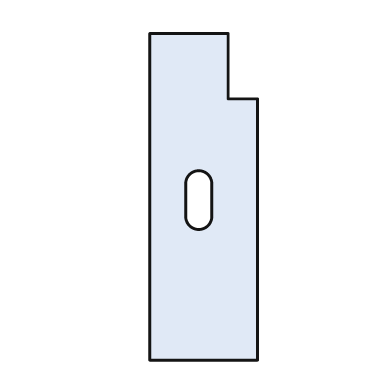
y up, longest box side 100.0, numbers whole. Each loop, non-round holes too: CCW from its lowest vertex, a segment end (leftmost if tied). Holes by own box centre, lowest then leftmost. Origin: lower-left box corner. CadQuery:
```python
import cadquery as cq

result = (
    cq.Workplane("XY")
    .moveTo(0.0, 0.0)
    .lineTo(33.0, 0.0)
    .lineTo(33.0, 80.0)
    .lineTo(24.0, 80.0)
    .lineTo(24.0, 100.0)
    .lineTo(0.0, 100.0)
    .close()
    .moveTo(11.0, 44.0)
    .threePointArc((15.0, 40.0), (19.0, 44.0))
    .lineTo(19.0, 54.0)
    .threePointArc((15.0, 58.0), (11.0, 54.0))
    .close()
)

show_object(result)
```